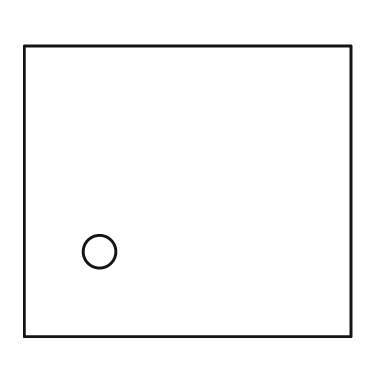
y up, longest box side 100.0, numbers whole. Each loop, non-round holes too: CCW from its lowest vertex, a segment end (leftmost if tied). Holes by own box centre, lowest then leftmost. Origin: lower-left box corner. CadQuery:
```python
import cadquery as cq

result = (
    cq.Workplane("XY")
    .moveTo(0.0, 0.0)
    .lineTo(100.0, 0.0)
    .lineTo(100.0, 89.0)
    .lineTo(0.0, 89.0)
    .close()
    .moveTo(23.0, 26.0)
    .circle(5.0)
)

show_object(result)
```